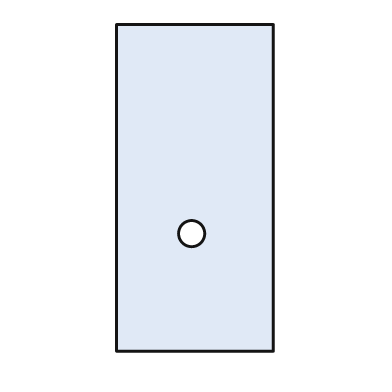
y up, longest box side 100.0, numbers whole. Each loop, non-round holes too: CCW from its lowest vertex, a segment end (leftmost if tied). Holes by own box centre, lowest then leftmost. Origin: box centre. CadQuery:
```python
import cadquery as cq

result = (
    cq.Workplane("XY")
    .moveTo(-24.0, -50.0)
    .lineTo(24.0, -50.0)
    .lineTo(24.0, 50.0)
    .lineTo(-24.0, 50.0)
    .close()
    .moveTo(-1.0, -14.0)
    .circle(4.0)
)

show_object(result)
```